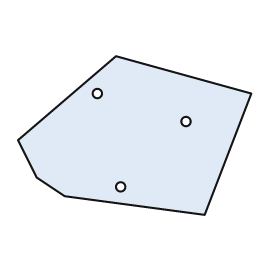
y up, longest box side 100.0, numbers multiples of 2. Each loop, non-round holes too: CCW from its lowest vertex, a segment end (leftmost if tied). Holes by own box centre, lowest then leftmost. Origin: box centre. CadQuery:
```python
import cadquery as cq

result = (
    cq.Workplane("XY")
    .moveTo(30.0, -34.0)
    .lineTo(50.0, 18.0)
    .lineTo(-8.0, 34.0)
    .lineTo(-50.0, -2.0)
    .lineTo(-42.0, -18.0)
    .lineTo(-30.0, -26.0)
    .close()
    .moveTo(-6.0, -22.0)
    .circle(2.0)
    .moveTo(22.0, 6.0)
    .circle(2.0)
    .moveTo(-16.0, 18.0)
    .circle(2.0)
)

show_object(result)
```